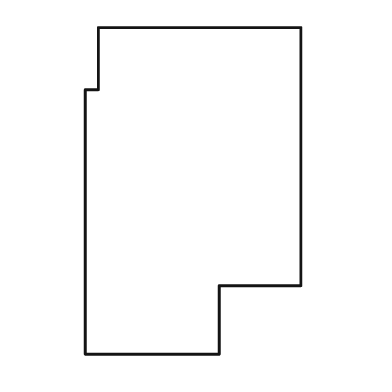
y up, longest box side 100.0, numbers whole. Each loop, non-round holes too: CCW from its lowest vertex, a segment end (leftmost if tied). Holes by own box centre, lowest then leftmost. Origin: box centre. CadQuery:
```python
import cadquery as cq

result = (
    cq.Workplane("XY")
    .moveTo(-33.0, -50.0)
    .lineTo(8.0, -50.0)
    .lineTo(8.0, -29.0)
    .lineTo(33.0, -29.0)
    .lineTo(33.0, 50.0)
    .lineTo(-29.0, 50.0)
    .lineTo(-29.0, 31.0)
    .lineTo(-33.0, 31.0)
    .close()
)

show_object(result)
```